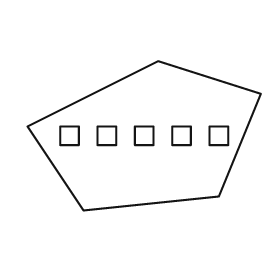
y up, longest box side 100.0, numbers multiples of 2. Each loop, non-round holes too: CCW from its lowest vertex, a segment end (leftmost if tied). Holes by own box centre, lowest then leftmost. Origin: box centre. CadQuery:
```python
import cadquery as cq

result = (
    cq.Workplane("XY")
    .moveTo(-26.0, -32.0)
    .lineTo(32.0, -26.0)
    .lineTo(50.0, 18.0)
    .lineTo(6.0, 32.0)
    .lineTo(-50.0, 4.0)
    .close()
    .moveTo(-36.0, -4.0)
    .lineTo(-28.0, -4.0)
    .lineTo(-28.0, 4.0)
    .lineTo(-36.0, 4.0)
    .close()
    .moveTo(-20.0, -4.0)
    .lineTo(-12.0, -4.0)
    .lineTo(-12.0, 4.0)
    .lineTo(-20.0, 4.0)
    .close()
    .moveTo(-4.0, -4.0)
    .lineTo(4.0, -4.0)
    .lineTo(4.0, 4.0)
    .lineTo(-4.0, 4.0)
    .close()
    .moveTo(12.0, -4.0)
    .lineTo(20.0, -4.0)
    .lineTo(20.0, 4.0)
    .lineTo(12.0, 4.0)
    .close()
    .moveTo(28.0, -4.0)
    .lineTo(36.0, -4.0)
    .lineTo(36.0, 4.0)
    .lineTo(28.0, 4.0)
    .close()
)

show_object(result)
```